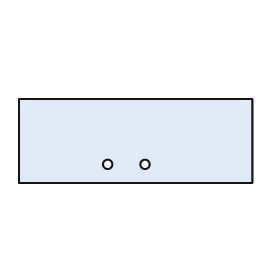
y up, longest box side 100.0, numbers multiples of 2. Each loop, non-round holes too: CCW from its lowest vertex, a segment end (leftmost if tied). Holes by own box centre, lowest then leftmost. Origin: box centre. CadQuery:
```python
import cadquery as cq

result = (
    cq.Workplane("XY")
    .moveTo(-50.0, -18.0)
    .lineTo(50.0, -18.0)
    .lineTo(50.0, 18.0)
    .lineTo(-50.0, 18.0)
    .close()
    .moveTo(-12.0, -10.0)
    .circle(2.0)
    .moveTo(4.0, -10.0)
    .circle(2.0)
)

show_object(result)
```